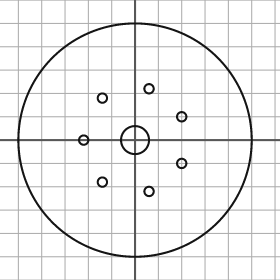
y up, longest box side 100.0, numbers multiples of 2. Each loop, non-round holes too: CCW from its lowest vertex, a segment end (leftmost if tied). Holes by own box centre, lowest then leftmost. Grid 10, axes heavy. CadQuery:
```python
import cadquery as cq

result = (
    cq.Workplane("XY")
    .moveTo(0.0, 0.0)
    .circle(50.0)
    .moveTo(6.0, -22.0)
    .circle(2.0)
    .moveTo(-14.0, -18.0)
    .circle(2.0)
    .moveTo(20.0, -10.0)
    .circle(2.0)
    .moveTo(-22.0, 0.0)
    .circle(2.0)
    .moveTo(0.0, 0.0)
    .circle(6.0)
    .moveTo(20.0, 10.0)
    .circle(2.0)
    .moveTo(-14.0, 18.0)
    .circle(2.0)
    .moveTo(6.0, 22.0)
    .circle(2.0)
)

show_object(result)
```